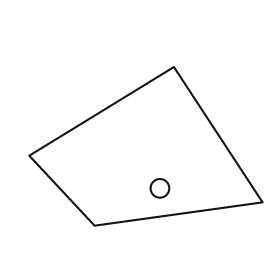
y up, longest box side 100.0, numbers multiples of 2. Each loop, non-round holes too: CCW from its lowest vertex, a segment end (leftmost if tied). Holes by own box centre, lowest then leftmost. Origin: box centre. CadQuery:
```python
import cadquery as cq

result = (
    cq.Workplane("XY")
    .moveTo(-22.0, -34.0)
    .lineTo(50.0, -24.0)
    .lineTo(12.0, 34.0)
    .lineTo(-50.0, -4.0)
    .close()
    .moveTo(6.0, -18.0)
    .circle(4.0)
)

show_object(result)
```